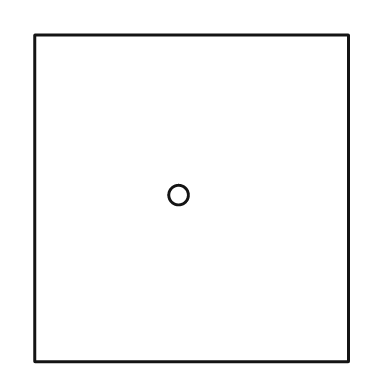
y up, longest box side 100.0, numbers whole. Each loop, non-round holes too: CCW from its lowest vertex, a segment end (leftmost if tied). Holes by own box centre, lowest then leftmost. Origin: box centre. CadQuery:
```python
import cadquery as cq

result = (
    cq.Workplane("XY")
    .moveTo(-48.0, -50.0)
    .lineTo(48.0, -50.0)
    .lineTo(48.0, 50.0)
    .lineTo(-48.0, 50.0)
    .close()
    .moveTo(-4.0, 1.0)
    .circle(3.0)
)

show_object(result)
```